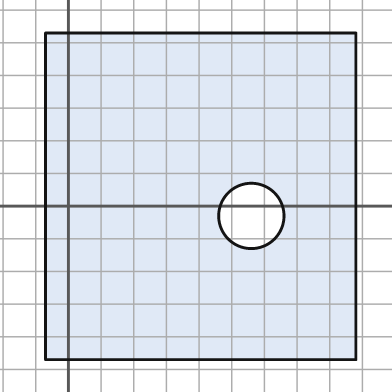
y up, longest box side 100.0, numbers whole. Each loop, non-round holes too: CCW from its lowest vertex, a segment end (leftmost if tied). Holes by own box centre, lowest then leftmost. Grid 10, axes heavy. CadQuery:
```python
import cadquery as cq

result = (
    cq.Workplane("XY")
    .moveTo(-7.0, -47.0)
    .lineTo(88.0, -47.0)
    .lineTo(88.0, 53.0)
    .lineTo(-7.0, 53.0)
    .close()
    .moveTo(56.0, -3.0)
    .circle(10.0)
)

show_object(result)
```